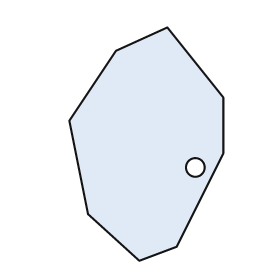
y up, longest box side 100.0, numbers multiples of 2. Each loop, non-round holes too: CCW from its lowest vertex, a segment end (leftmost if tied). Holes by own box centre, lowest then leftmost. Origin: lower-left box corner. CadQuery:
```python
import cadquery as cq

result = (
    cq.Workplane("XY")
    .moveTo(30.0, 0.0)
    .lineTo(46.0, 6.0)
    .lineTo(66.0, 46.0)
    .lineTo(66.0, 70.0)
    .lineTo(42.0, 100.0)
    .lineTo(20.0, 90.0)
    .lineTo(0.0, 60.0)
    .lineTo(8.0, 20.0)
    .close()
    .moveTo(54.0, 40.0)
    .circle(4.0)
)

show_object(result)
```